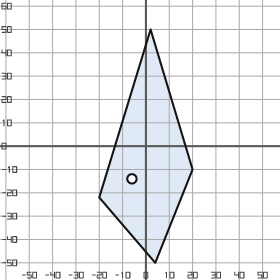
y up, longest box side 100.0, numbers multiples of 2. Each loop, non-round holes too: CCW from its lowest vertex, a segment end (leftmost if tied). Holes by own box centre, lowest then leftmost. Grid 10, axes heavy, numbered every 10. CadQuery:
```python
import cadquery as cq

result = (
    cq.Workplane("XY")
    .moveTo(4.0, -50.0)
    .lineTo(20.0, -10.0)
    .lineTo(2.0, 50.0)
    .lineTo(-20.0, -22.0)
    .close()
    .moveTo(-6.0, -14.0)
    .circle(2.0)
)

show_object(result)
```